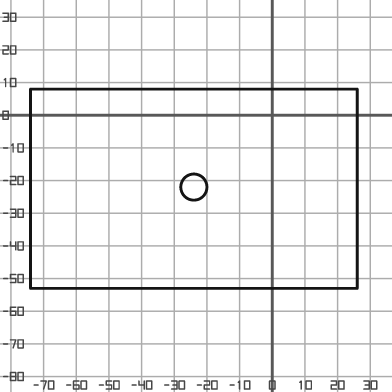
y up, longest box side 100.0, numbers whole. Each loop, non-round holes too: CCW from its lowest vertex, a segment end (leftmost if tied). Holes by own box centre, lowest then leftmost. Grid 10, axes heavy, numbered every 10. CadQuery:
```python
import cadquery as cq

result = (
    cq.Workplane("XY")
    .moveTo(-74.0, -53.0)
    .lineTo(26.0, -53.0)
    .lineTo(26.0, 8.0)
    .lineTo(-74.0, 8.0)
    .close()
    .moveTo(-24.0, -22.0)
    .circle(4.0)
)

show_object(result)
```